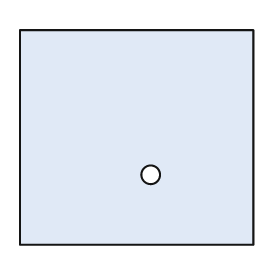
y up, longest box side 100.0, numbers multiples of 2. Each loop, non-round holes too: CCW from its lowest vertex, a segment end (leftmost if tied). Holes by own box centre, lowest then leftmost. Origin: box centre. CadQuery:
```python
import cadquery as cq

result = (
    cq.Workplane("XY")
    .moveTo(-50.0, -46.0)
    .lineTo(50.0, -46.0)
    .lineTo(50.0, 46.0)
    .lineTo(-50.0, 46.0)
    .close()
    .moveTo(6.0, -16.0)
    .circle(4.0)
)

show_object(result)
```